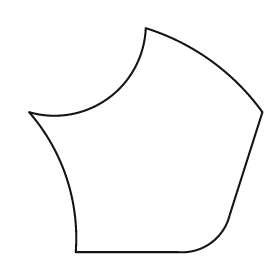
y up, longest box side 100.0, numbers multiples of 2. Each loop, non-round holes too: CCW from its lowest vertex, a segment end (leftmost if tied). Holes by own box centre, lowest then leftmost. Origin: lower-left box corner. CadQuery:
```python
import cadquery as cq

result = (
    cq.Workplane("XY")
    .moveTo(20.0, 0.0)
    .lineTo(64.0, 0.0)
    .threePointArc((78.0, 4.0), (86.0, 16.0))
    .lineTo(100.0, 60.0)
    .threePointArc((78.0, 82.0), (50.0, 96.0))
    .threePointArc((34.0, 66.0), (0.0, 60.0))
    .threePointArc((16.0, 32.0), (20.0, 0.0))
    .close()
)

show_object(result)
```